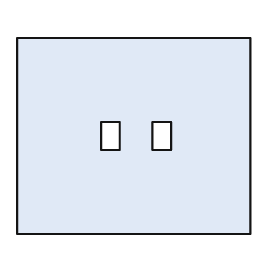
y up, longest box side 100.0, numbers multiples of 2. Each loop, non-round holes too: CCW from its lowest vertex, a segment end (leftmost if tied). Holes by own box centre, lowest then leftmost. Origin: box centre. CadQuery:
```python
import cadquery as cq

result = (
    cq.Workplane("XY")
    .moveTo(-50.0, -42.0)
    .lineTo(50.0, -42.0)
    .lineTo(50.0, 42.0)
    .lineTo(-50.0, 42.0)
    .close()
    .moveTo(-14.0, -6.0)
    .lineTo(-6.0, -6.0)
    .lineTo(-6.0, 6.0)
    .lineTo(-14.0, 6.0)
    .close()
    .moveTo(8.0, -6.0)
    .lineTo(16.0, -6.0)
    .lineTo(16.0, 6.0)
    .lineTo(8.0, 6.0)
    .close()
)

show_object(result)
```